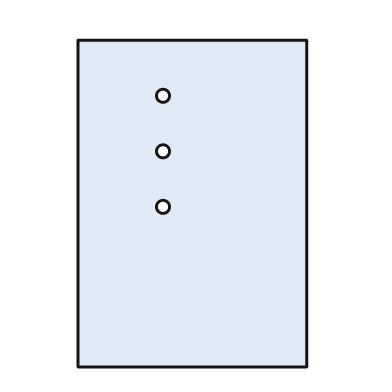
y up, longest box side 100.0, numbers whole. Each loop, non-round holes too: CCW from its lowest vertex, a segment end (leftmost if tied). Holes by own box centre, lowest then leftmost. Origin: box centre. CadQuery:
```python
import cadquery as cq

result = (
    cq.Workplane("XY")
    .moveTo(-35.0, -50.0)
    .lineTo(35.0, -50.0)
    .lineTo(35.0, 50.0)
    .lineTo(-35.0, 50.0)
    .close()
    .moveTo(-9.0, -1.0)
    .circle(2.0)
    .moveTo(-9.0, 16.0)
    .circle(2.0)
    .moveTo(-9.0, 33.0)
    .circle(2.0)
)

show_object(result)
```